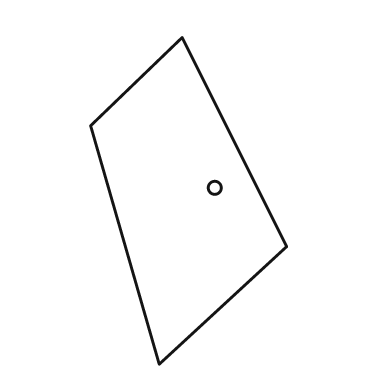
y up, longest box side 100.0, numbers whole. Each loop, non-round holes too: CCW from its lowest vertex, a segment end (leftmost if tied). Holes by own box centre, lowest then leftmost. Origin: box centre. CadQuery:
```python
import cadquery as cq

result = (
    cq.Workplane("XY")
    .moveTo(-9.0, -50.0)
    .lineTo(30.0, -14.0)
    .lineTo(-2.0, 50.0)
    .lineTo(-30.0, 23.0)
    .close()
    .moveTo(8.0, 4.0)
    .circle(2.0)
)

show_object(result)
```